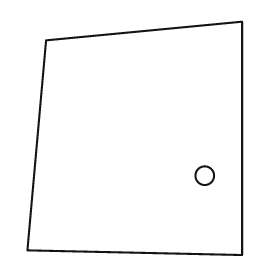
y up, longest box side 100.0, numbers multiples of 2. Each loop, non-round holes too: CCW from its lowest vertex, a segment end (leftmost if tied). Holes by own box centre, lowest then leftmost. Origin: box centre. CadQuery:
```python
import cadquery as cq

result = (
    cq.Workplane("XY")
    .moveTo(46.0, -50.0)
    .lineTo(46.0, 50.0)
    .lineTo(-38.0, 42.0)
    .lineTo(-46.0, -48.0)
    .close()
    .moveTo(30.0, -16.0)
    .circle(4.0)
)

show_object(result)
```